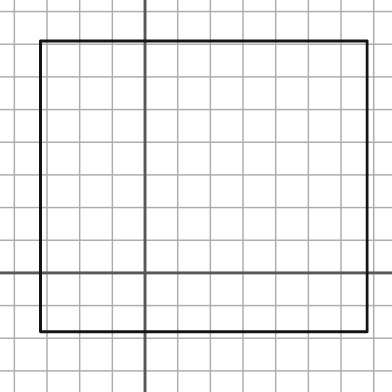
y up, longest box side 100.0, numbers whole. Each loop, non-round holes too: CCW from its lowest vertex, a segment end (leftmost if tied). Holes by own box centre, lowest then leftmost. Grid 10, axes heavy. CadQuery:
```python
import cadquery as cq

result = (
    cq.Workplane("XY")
    .moveTo(-32.0, -18.0)
    .lineTo(68.0, -18.0)
    .lineTo(68.0, 71.0)
    .lineTo(-32.0, 71.0)
    .close()
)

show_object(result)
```